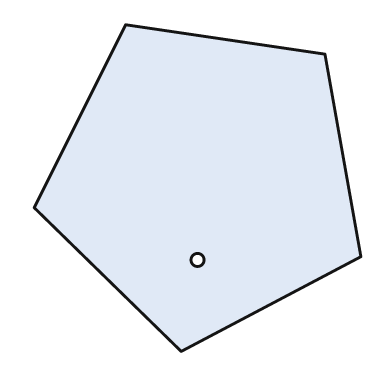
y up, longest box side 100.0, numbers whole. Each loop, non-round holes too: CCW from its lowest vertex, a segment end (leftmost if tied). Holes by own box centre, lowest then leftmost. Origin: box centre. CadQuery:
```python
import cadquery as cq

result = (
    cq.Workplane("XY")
    .moveTo(-5.0, -50.0)
    .lineTo(50.0, -21.0)
    .lineTo(39.0, 41.0)
    .lineTo(-22.0, 50.0)
    .lineTo(-50.0, -6.0)
    .close()
    .moveTo(0.0, -22.0)
    .circle(2.0)
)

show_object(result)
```